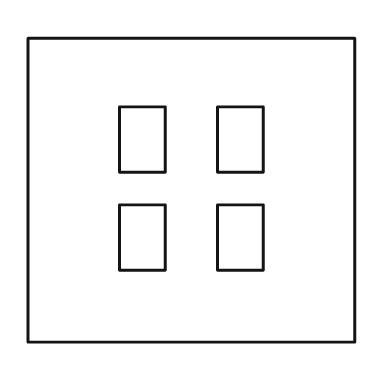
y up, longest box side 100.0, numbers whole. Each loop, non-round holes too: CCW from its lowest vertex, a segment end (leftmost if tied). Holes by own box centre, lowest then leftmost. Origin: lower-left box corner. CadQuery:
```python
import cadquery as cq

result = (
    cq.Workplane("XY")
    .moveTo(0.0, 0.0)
    .lineTo(100.0, 0.0)
    .lineTo(100.0, 93.0)
    .lineTo(0.0, 93.0)
    .close()
    .moveTo(28.0, 22.0)
    .lineTo(42.0, 22.0)
    .lineTo(42.0, 42.0)
    .lineTo(28.0, 42.0)
    .close()
    .moveTo(58.0, 22.0)
    .lineTo(72.0, 22.0)
    .lineTo(72.0, 42.0)
    .lineTo(58.0, 42.0)
    .close()
    .moveTo(28.0, 52.0)
    .lineTo(42.0, 52.0)
    .lineTo(42.0, 72.0)
    .lineTo(28.0, 72.0)
    .close()
    .moveTo(58.0, 52.0)
    .lineTo(72.0, 52.0)
    .lineTo(72.0, 72.0)
    .lineTo(58.0, 72.0)
    .close()
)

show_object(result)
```